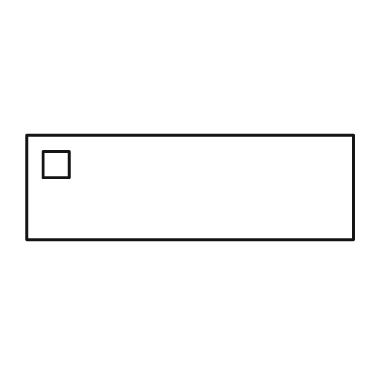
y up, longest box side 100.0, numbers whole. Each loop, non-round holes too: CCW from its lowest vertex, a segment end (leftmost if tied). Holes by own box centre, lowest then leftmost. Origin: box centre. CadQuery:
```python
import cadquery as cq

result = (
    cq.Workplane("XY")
    .moveTo(-50.0, -16.0)
    .lineTo(50.0, -16.0)
    .lineTo(50.0, 16.0)
    .lineTo(-50.0, 16.0)
    .close()
    .moveTo(-45.0, 3.0)
    .lineTo(-37.0, 3.0)
    .lineTo(-37.0, 11.0)
    .lineTo(-45.0, 11.0)
    .close()
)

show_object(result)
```